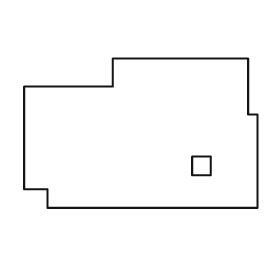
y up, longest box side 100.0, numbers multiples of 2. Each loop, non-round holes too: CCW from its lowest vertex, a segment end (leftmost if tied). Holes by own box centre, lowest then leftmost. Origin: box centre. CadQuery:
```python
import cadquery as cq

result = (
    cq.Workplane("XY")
    .moveTo(-40.0, -32.0)
    .lineTo(50.0, -32.0)
    .lineTo(50.0, 8.0)
    .lineTo(46.0, 8.0)
    .lineTo(46.0, 32.0)
    .lineTo(-12.0, 32.0)
    .lineTo(-12.0, 20.0)
    .lineTo(-50.0, 20.0)
    .lineTo(-50.0, -24.0)
    .lineTo(-40.0, -24.0)
    .close()
    .moveTo(22.0, -18.0)
    .lineTo(30.0, -18.0)
    .lineTo(30.0, -10.0)
    .lineTo(22.0, -10.0)
    .close()
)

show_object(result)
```